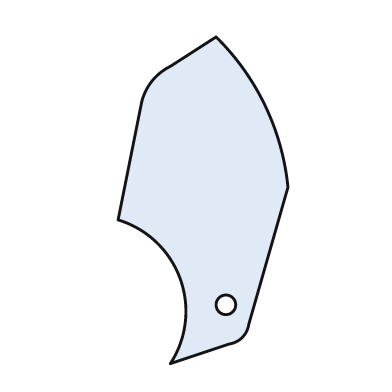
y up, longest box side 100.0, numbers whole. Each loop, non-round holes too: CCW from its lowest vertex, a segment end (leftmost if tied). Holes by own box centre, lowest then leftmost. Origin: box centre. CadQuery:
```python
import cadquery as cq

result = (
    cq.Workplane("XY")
    .moveTo(-10.0, -50.0)
    .lineTo(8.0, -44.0)
    .threePointArc((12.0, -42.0), (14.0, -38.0))
    .lineTo(26.0, 4.0)
    .threePointArc((19.0, 29.0), (4.0, 50.0))
    .lineTo(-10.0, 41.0)
    .threePointArc((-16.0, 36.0), (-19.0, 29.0))
    .lineTo(-26.0, -6.0)
    .threePointArc((-7.0, -24.0), (-10.0, -50.0))
    .close()
    .moveTo(7.0, -32.0)
    .circle(3.0)
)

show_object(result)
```